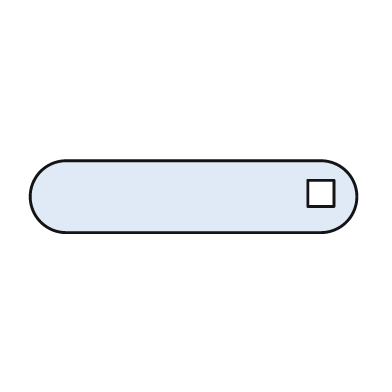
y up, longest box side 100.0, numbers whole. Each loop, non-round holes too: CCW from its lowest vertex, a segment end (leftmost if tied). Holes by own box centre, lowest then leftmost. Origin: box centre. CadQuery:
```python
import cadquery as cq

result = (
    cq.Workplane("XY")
    .moveTo(-39.0, -11.0)
    .lineTo(39.0, -11.0)
    .threePointArc((50.0, 0.0), (39.0, 11.0))
    .lineTo(-39.0, 11.0)
    .threePointArc((-50.0, 0.0), (-39.0, -11.0))
    .close()
    .moveTo(35.0, -3.0)
    .lineTo(43.0, -3.0)
    .lineTo(43.0, 5.0)
    .lineTo(35.0, 5.0)
    .close()
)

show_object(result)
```